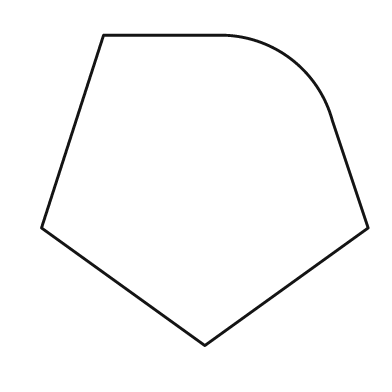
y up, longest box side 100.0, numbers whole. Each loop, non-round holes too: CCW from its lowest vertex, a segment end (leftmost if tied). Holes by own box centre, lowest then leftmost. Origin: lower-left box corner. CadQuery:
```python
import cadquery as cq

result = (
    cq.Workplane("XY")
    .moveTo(50.0, 0.0)
    .lineTo(100.0, 36.0)
    .lineTo(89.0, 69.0)
    .threePointArc((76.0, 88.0), (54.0, 95.0))
    .lineTo(19.0, 95.0)
    .lineTo(0.0, 36.0)
    .close()
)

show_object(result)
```